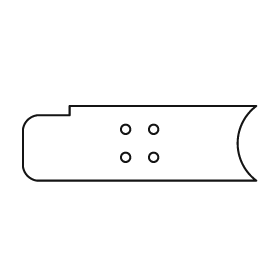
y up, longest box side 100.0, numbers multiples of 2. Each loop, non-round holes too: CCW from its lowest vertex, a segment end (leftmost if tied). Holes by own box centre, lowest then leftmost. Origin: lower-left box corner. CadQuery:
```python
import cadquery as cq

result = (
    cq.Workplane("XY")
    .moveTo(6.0, 0.0)
    .lineTo(100.0, 0.0)
    .threePointArc((92.0, 16.0), (100.0, 32.0))
    .lineTo(20.0, 32.0)
    .lineTo(20.0, 28.0)
    .lineTo(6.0, 28.0)
    .threePointArc((2.0, 26.0), (0.0, 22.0))
    .lineTo(0.0, 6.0)
    .threePointArc((2.0, 2.0), (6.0, 0.0))
    .close()
    .moveTo(44.0, 10.0)
    .circle(2.0)
    .moveTo(56.0, 10.0)
    .circle(2.0)
    .moveTo(44.0, 22.0)
    .circle(2.0)
    .moveTo(56.0, 22.0)
    .circle(2.0)
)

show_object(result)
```